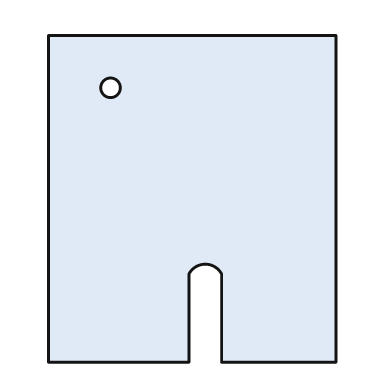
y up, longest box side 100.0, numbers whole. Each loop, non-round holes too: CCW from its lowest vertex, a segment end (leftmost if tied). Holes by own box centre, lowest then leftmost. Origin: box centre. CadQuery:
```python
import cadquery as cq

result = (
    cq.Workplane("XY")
    .moveTo(-44.0, -50.0)
    .lineTo(-1.0, -50.0)
    .lineTo(-1.0, -23.0)
    .threePointArc((4.0, -20.0), (9.0, -23.0))
    .lineTo(9.0, -50.0)
    .lineTo(44.0, -50.0)
    .lineTo(44.0, 50.0)
    .lineTo(-44.0, 50.0)
    .close()
    .moveTo(-25.0, 34.0)
    .circle(3.0)
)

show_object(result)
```